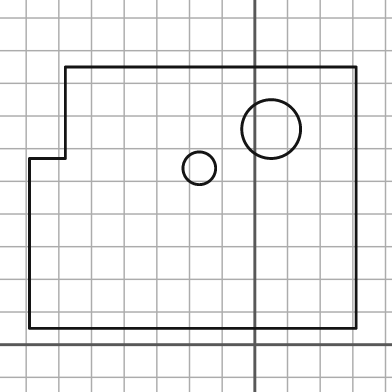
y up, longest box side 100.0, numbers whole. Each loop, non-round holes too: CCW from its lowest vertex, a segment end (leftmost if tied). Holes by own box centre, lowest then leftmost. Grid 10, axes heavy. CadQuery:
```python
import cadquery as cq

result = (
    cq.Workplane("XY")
    .moveTo(-69.0, 5.0)
    .lineTo(31.0, 5.0)
    .lineTo(31.0, 85.0)
    .lineTo(-58.0, 85.0)
    .lineTo(-58.0, 57.0)
    .lineTo(-69.0, 57.0)
    .close()
    .moveTo(-17.0, 54.0)
    .circle(5.0)
    .moveTo(5.0, 66.0)
    .circle(9.0)
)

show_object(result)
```